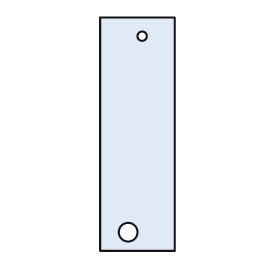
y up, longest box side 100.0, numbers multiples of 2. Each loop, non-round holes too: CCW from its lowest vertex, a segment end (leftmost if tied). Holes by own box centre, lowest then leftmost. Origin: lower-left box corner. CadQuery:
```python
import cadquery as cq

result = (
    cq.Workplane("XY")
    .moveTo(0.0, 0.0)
    .lineTo(32.0, 0.0)
    .lineTo(32.0, 100.0)
    .lineTo(0.0, 100.0)
    .close()
    .moveTo(12.0, 8.0)
    .circle(4.0)
    .moveTo(18.0, 92.0)
    .circle(2.0)
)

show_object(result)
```